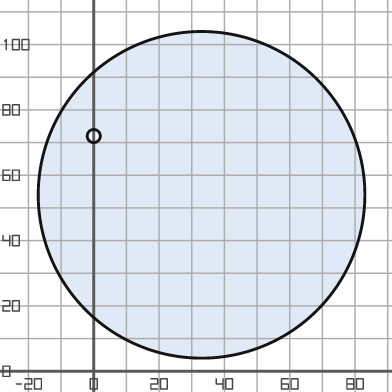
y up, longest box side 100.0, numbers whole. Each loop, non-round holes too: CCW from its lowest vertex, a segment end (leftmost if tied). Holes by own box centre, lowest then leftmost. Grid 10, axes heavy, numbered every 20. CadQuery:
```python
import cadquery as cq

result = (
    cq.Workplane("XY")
    .moveTo(33.0, 54.0)
    .circle(50.0)
    .moveTo(0.0, 72.0)
    .circle(2.0)
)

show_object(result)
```